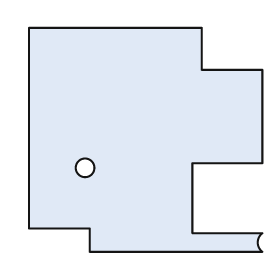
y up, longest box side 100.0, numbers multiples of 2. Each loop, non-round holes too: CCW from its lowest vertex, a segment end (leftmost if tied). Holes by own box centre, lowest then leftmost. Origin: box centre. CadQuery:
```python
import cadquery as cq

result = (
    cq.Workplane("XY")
    .moveTo(-24.0, -48.0)
    .lineTo(50.0, -48.0)
    .threePointArc((48.0, -44.0), (50.0, -40.0))
    .lineTo(20.0, -40.0)
    .lineTo(20.0, -10.0)
    .lineTo(50.0, -10.0)
    .lineTo(50.0, 30.0)
    .lineTo(24.0, 30.0)
    .lineTo(24.0, 48.0)
    .lineTo(-50.0, 48.0)
    .lineTo(-50.0, -38.0)
    .lineTo(-24.0, -38.0)
    .close()
    .moveTo(-26.0, -12.0)
    .circle(4.0)
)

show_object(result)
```